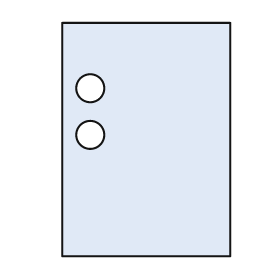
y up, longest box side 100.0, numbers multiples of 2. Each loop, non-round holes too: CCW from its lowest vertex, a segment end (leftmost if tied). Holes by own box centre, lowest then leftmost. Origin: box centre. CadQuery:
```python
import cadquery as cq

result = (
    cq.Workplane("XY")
    .moveTo(-36.0, -50.0)
    .lineTo(36.0, -50.0)
    .lineTo(36.0, 50.0)
    .lineTo(-36.0, 50.0)
    .close()
    .moveTo(-24.0, 2.0)
    .circle(6.0)
    .moveTo(-24.0, 22.0)
    .circle(6.0)
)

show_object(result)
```